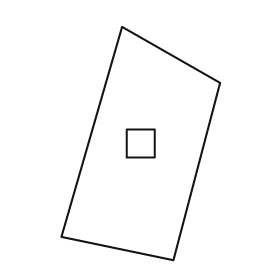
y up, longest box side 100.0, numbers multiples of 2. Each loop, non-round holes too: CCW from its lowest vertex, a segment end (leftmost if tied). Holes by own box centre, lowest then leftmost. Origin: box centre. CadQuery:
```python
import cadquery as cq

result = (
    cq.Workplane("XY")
    .moveTo(14.0, -50.0)
    .lineTo(34.0, 26.0)
    .lineTo(-8.0, 50.0)
    .lineTo(-34.0, -40.0)
    .close()
    .moveTo(-6.0, -6.0)
    .lineTo(6.0, -6.0)
    .lineTo(6.0, 6.0)
    .lineTo(-6.0, 6.0)
    .close()
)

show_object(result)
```